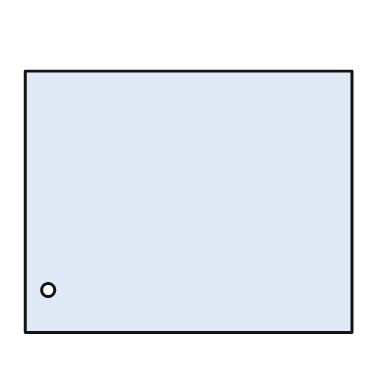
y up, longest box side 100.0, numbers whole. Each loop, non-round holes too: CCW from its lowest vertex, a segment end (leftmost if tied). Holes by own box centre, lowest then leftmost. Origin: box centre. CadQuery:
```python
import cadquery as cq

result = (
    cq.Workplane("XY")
    .moveTo(-50.0, -40.0)
    .lineTo(50.0, -40.0)
    .lineTo(50.0, 40.0)
    .lineTo(-50.0, 40.0)
    .close()
    .moveTo(-43.0, -27.0)
    .circle(2.0)
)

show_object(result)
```